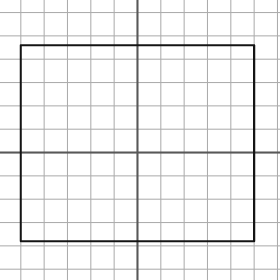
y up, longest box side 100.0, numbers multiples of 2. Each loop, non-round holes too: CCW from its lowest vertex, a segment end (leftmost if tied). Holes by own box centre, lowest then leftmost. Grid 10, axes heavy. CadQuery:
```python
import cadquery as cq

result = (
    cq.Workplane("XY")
    .moveTo(-50.0, -38.0)
    .lineTo(50.0, -38.0)
    .lineTo(50.0, 46.0)
    .lineTo(-50.0, 46.0)
    .close()
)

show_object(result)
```